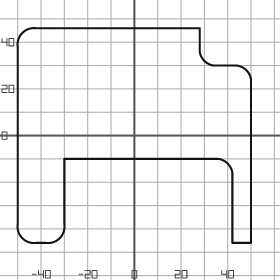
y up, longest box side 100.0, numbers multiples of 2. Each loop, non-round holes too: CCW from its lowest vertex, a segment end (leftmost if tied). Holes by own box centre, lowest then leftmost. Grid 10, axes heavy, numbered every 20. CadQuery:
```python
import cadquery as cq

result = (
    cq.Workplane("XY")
    .moveTo(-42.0, -46.0)
    .lineTo(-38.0, -46.0)
    .threePointArc((-32.0, -44.0), (-30.0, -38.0))
    .lineTo(-30.0, -10.0)
    .lineTo(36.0, -10.0)
    .threePointArc((40.0, -12.0), (42.0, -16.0))
    .lineTo(42.0, -46.0)
    .lineTo(50.0, -46.0)
    .lineTo(50.0, 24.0)
    .threePointArc((48.0, 28.0), (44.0, 30.0))
    .lineTo(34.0, 30.0)
    .threePointArc((30.0, 32.0), (28.0, 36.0))
    .lineTo(28.0, 46.0)
    .lineTo(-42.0, 46.0)
    .threePointArc((-48.0, 44.0), (-50.0, 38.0))
    .lineTo(-50.0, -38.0)
    .threePointArc((-48.0, -44.0), (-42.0, -46.0))
    .close()
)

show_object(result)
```